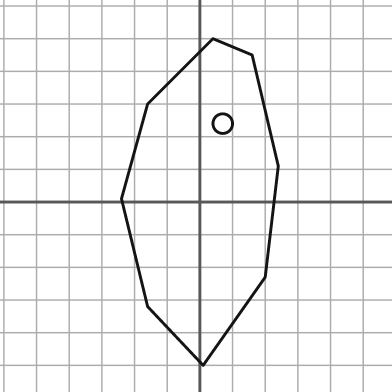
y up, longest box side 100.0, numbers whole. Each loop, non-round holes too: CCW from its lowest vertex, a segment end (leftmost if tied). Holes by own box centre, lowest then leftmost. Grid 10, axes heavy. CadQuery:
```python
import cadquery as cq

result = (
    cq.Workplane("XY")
    .moveTo(1.0, -50.0)
    .lineTo(20.0, -23.0)
    .lineTo(24.0, 11.0)
    .lineTo(16.0, 45.0)
    .lineTo(4.0, 50.0)
    .lineTo(-16.0, 30.0)
    .lineTo(-24.0, 1.0)
    .lineTo(-16.0, -32.0)
    .close()
    .moveTo(7.0, 24.0)
    .circle(3.0)
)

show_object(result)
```